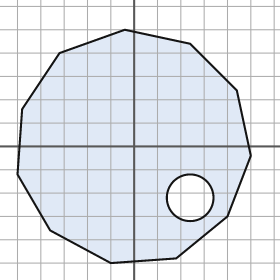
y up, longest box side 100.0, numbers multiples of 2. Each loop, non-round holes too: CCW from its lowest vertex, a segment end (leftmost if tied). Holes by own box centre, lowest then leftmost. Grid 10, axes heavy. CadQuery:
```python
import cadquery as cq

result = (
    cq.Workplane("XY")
    .moveTo(-10.0, -50.0)
    .lineTo(18.0, -48.0)
    .lineTo(40.0, -30.0)
    .lineTo(50.0, -4.0)
    .lineTo(44.0, 24.0)
    .lineTo(24.0, 44.0)
    .lineTo(-4.0, 50.0)
    .lineTo(-32.0, 40.0)
    .lineTo(-48.0, 16.0)
    .lineTo(-50.0, -12.0)
    .lineTo(-36.0, -36.0)
    .close()
    .moveTo(24.0, -22.0)
    .circle(10.0)
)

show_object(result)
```